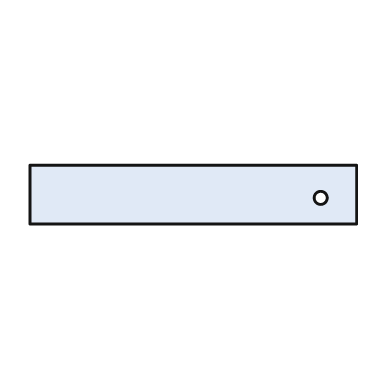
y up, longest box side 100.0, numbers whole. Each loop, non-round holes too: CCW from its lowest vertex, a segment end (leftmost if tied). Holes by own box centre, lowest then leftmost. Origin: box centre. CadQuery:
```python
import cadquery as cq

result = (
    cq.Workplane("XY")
    .moveTo(-50.0, -9.0)
    .lineTo(50.0, -9.0)
    .lineTo(50.0, 9.0)
    .lineTo(-50.0, 9.0)
    .close()
    .moveTo(39.0, -1.0)
    .circle(2.0)
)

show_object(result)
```